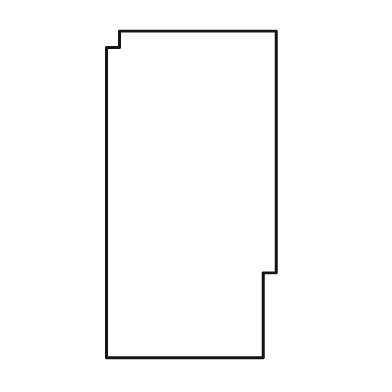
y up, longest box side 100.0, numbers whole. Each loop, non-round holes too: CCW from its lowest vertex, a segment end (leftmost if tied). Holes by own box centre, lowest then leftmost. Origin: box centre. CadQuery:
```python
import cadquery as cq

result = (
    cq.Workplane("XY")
    .moveTo(-26.0, -50.0)
    .lineTo(22.0, -50.0)
    .lineTo(22.0, -24.0)
    .lineTo(26.0, -24.0)
    .lineTo(26.0, 50.0)
    .lineTo(-22.0, 50.0)
    .lineTo(-22.0, 45.0)
    .lineTo(-26.0, 45.0)
    .close()
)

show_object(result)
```